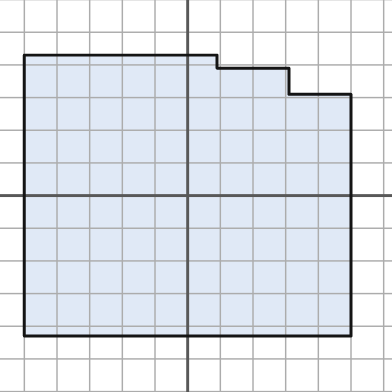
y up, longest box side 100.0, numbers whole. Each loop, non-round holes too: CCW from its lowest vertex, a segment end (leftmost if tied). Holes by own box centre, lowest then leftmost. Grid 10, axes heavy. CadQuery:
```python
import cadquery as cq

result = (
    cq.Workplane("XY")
    .moveTo(-50.0, -43.0)
    .lineTo(50.0, -43.0)
    .lineTo(50.0, 31.0)
    .lineTo(31.0, 31.0)
    .lineTo(31.0, 39.0)
    .lineTo(9.0, 39.0)
    .lineTo(9.0, 43.0)
    .lineTo(-50.0, 43.0)
    .close()
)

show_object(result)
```